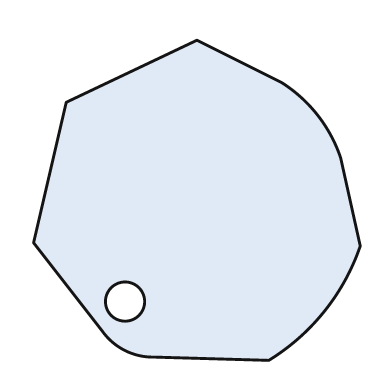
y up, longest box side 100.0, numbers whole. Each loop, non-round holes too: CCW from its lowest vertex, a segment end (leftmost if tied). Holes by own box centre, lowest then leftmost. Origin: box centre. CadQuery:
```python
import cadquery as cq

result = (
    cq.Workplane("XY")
    .moveTo(22.0, -49.0)
    .threePointArc((39.0, -34.0), (50.0, -14.0))
    .lineTo(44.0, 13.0)
    .threePointArc((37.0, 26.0), (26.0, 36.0))
    .lineTo(0.0, 49.0)
    .lineTo(-40.0, 30.0)
    .lineTo(-50.0, -13.0)
    .lineTo(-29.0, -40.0)
    .threePointArc((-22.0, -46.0), (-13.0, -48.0))
    .close()
    .moveTo(-22.0, -31.0)
    .circle(6.0)
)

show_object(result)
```